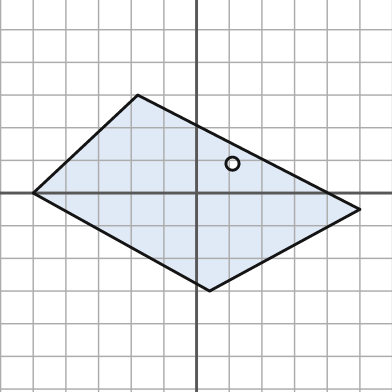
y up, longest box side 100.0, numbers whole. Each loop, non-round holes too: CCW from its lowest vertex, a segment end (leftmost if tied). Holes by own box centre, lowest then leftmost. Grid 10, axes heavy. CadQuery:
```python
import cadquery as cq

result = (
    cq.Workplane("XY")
    .moveTo(4.0, -30.0)
    .lineTo(50.0, -5.0)
    .lineTo(-18.0, 30.0)
    .lineTo(-50.0, 0.0)
    .close()
    .moveTo(11.0, 9.0)
    .circle(2.0)
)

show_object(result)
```